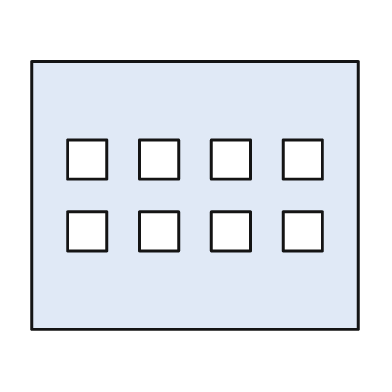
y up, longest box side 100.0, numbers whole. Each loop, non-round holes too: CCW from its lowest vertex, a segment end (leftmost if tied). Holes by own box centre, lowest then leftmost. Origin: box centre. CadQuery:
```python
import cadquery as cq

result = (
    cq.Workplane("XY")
    .moveTo(-50.0, -41.0)
    .lineTo(50.0, -41.0)
    .lineTo(50.0, 41.0)
    .lineTo(-50.0, 41.0)
    .close()
    .moveTo(-39.0, -17.0)
    .lineTo(-27.0, -17.0)
    .lineTo(-27.0, -5.0)
    .lineTo(-39.0, -5.0)
    .close()
    .moveTo(-17.0, -17.0)
    .lineTo(-5.0, -17.0)
    .lineTo(-5.0, -5.0)
    .lineTo(-17.0, -5.0)
    .close()
    .moveTo(5.0, -17.0)
    .lineTo(17.0, -17.0)
    .lineTo(17.0, -5.0)
    .lineTo(5.0, -5.0)
    .close()
    .moveTo(27.0, -17.0)
    .lineTo(39.0, -17.0)
    .lineTo(39.0, -5.0)
    .lineTo(27.0, -5.0)
    .close()
    .moveTo(-39.0, 5.0)
    .lineTo(-27.0, 5.0)
    .lineTo(-27.0, 17.0)
    .lineTo(-39.0, 17.0)
    .close()
    .moveTo(-17.0, 5.0)
    .lineTo(-5.0, 5.0)
    .lineTo(-5.0, 17.0)
    .lineTo(-17.0, 17.0)
    .close()
    .moveTo(5.0, 5.0)
    .lineTo(17.0, 5.0)
    .lineTo(17.0, 17.0)
    .lineTo(5.0, 17.0)
    .close()
    .moveTo(27.0, 5.0)
    .lineTo(39.0, 5.0)
    .lineTo(39.0, 17.0)
    .lineTo(27.0, 17.0)
    .close()
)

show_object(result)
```